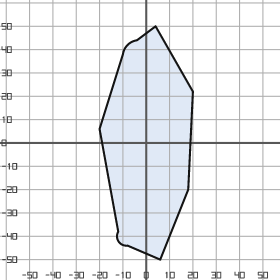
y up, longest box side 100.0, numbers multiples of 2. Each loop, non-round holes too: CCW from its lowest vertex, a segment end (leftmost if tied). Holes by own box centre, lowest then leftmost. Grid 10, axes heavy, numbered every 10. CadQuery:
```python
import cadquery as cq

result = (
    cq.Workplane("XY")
    .moveTo(6.0, -50.0)
    .lineTo(18.0, -20.0)
    .lineTo(20.0, 22.0)
    .lineTo(4.0, 50.0)
    .lineTo(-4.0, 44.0)
    .threePointArc((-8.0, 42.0), (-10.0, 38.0))
    .lineTo(-20.0, 6.0)
    .lineTo(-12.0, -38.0)
    .threePointArc((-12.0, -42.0), (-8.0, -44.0))
    .close()
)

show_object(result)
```